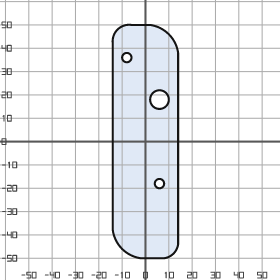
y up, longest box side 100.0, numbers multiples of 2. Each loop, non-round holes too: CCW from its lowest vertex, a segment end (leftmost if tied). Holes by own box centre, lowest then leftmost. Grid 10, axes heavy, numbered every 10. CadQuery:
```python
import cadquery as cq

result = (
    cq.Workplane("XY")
    .moveTo(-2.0, -50.0)
    .lineTo(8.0, -50.0)
    .threePointArc((12.0, -48.0), (14.0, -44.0))
    .lineTo(14.0, 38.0)
    .threePointArc((10.0, 46.0), (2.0, 50.0))
    .lineTo(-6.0, 50.0)
    .threePointArc((-12.0, 48.0), (-14.0, 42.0))
    .lineTo(-14.0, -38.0)
    .threePointArc((-10.0, -46.0), (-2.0, -50.0))
    .close()
    .moveTo(6.0, -18.0)
    .circle(2.0)
    .moveTo(6.0, 18.0)
    .circle(4.0)
    .moveTo(-8.0, 36.0)
    .circle(2.0)
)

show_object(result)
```